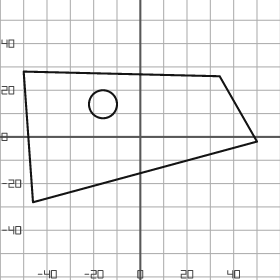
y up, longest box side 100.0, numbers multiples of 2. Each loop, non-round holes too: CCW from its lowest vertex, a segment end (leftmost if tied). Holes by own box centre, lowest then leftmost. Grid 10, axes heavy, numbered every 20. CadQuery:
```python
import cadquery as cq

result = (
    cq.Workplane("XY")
    .moveTo(-46.0, -28.0)
    .lineTo(50.0, -2.0)
    .lineTo(34.0, 26.0)
    .lineTo(-50.0, 28.0)
    .close()
    .moveTo(-16.0, 14.0)
    .circle(6.0)
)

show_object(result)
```